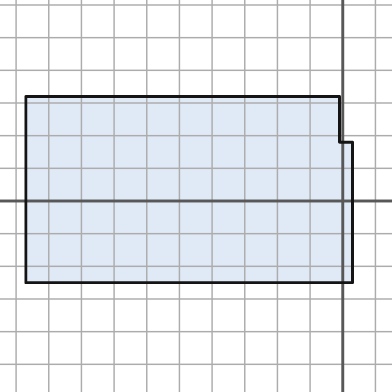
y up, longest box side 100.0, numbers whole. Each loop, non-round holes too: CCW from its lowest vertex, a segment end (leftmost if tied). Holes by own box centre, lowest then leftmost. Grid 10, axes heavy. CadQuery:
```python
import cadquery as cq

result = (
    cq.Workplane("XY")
    .moveTo(-97.0, -25.0)
    .lineTo(3.0, -25.0)
    .lineTo(3.0, 18.0)
    .lineTo(-1.0, 18.0)
    .lineTo(-1.0, 32.0)
    .lineTo(-97.0, 32.0)
    .close()
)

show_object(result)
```